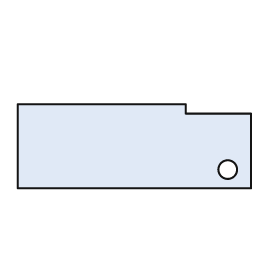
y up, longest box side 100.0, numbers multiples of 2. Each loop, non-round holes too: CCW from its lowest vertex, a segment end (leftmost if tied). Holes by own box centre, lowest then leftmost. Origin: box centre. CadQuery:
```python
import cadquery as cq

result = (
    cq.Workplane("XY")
    .moveTo(-50.0, -18.0)
    .lineTo(50.0, -18.0)
    .lineTo(50.0, 14.0)
    .lineTo(22.0, 14.0)
    .lineTo(22.0, 18.0)
    .lineTo(-50.0, 18.0)
    .close()
    .moveTo(40.0, -10.0)
    .circle(4.0)
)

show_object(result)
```